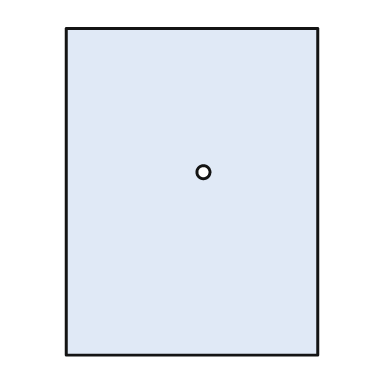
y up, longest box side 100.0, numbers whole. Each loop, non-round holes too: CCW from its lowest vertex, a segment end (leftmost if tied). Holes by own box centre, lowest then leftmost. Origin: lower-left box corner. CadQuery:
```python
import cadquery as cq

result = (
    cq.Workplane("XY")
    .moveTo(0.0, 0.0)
    .lineTo(77.0, 0.0)
    .lineTo(77.0, 100.0)
    .lineTo(0.0, 100.0)
    .close()
    .moveTo(42.0, 56.0)
    .circle(2.0)
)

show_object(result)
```